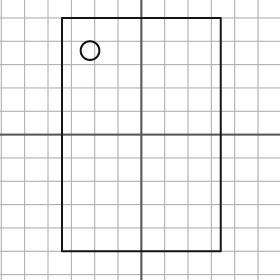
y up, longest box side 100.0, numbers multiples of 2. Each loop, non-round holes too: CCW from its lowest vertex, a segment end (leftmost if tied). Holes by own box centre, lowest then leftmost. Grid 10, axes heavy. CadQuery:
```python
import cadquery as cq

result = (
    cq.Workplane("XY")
    .moveTo(-34.0, -50.0)
    .lineTo(34.0, -50.0)
    .lineTo(34.0, 50.0)
    .lineTo(-34.0, 50.0)
    .close()
    .moveTo(-22.0, 36.0)
    .circle(4.0)
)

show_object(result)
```